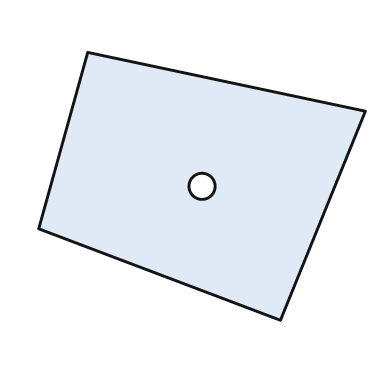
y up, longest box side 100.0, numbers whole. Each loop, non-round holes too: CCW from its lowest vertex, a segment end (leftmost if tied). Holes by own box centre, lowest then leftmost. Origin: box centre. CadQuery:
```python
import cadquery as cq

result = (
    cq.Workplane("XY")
    .moveTo(24.0, -41.0)
    .lineTo(50.0, 23.0)
    .lineTo(-35.0, 41.0)
    .lineTo(-50.0, -13.0)
    .close()
    .moveTo(0.0, 0.0)
    .circle(4.0)
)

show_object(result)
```